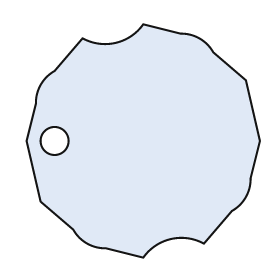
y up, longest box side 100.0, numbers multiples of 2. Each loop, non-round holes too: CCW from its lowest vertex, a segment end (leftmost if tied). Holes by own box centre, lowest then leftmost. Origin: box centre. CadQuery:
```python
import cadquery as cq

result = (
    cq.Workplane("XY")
    .moveTo(0.0, -50.0)
    .threePointArc((12.0, -42.0), (26.0, -44.0))
    .lineTo(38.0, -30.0)
    .threePointArc((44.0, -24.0), (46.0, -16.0))
    .lineTo(50.0, 0.0)
    .lineTo(44.0, 26.0)
    .lineTo(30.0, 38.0)
    .threePointArc((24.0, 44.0), (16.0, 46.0))
    .lineTo(0.0, 50.0)
    .threePointArc((-12.0, 42.0), (-26.0, 44.0))
    .lineTo(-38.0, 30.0)
    .threePointArc((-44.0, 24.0), (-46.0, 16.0))
    .lineTo(-50.0, 0.0)
    .lineTo(-44.0, -26.0)
    .lineTo(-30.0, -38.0)
    .threePointArc((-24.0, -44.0), (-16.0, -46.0))
    .close()
    .moveTo(-38.0, 0.0)
    .circle(6.0)
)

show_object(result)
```